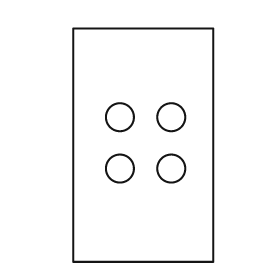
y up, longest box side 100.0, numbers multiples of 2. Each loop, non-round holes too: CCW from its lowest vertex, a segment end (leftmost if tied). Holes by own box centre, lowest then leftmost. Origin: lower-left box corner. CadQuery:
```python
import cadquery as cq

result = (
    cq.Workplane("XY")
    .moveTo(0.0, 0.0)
    .lineTo(60.0, 0.0)
    .lineTo(60.0, 100.0)
    .lineTo(0.0, 100.0)
    .close()
    .moveTo(20.0, 40.0)
    .circle(6.0)
    .moveTo(42.0, 40.0)
    .circle(6.0)
    .moveTo(20.0, 62.0)
    .circle(6.0)
    .moveTo(42.0, 62.0)
    .circle(6.0)
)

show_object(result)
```